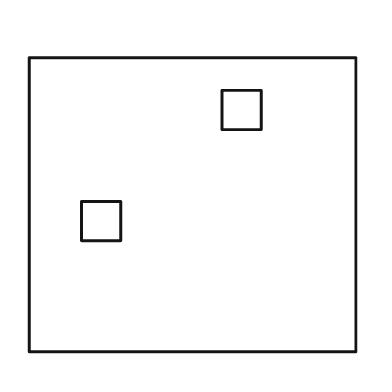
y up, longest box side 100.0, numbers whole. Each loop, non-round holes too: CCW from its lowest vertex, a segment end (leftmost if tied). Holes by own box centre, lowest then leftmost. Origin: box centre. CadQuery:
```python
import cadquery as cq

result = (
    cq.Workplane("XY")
    .moveTo(-50.0, -45.0)
    .lineTo(50.0, -45.0)
    .lineTo(50.0, 45.0)
    .lineTo(-50.0, 45.0)
    .close()
    .moveTo(-34.0, -11.0)
    .lineTo(-22.0, -11.0)
    .lineTo(-22.0, 1.0)
    .lineTo(-34.0, 1.0)
    .close()
    .moveTo(9.0, 23.0)
    .lineTo(21.0, 23.0)
    .lineTo(21.0, 35.0)
    .lineTo(9.0, 35.0)
    .close()
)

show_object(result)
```